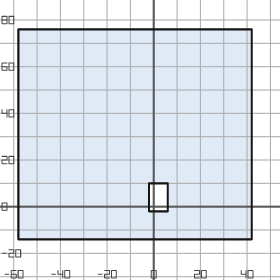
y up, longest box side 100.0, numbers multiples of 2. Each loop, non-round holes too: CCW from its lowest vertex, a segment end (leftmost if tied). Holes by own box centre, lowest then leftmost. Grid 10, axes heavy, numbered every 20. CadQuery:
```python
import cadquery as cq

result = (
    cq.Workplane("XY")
    .moveTo(-58.0, -14.0)
    .lineTo(42.0, -14.0)
    .lineTo(42.0, 76.0)
    .lineTo(-58.0, 76.0)
    .close()
    .moveTo(-2.0, -2.0)
    .lineTo(6.0, -2.0)
    .lineTo(6.0, 10.0)
    .lineTo(-2.0, 10.0)
    .close()
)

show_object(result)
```